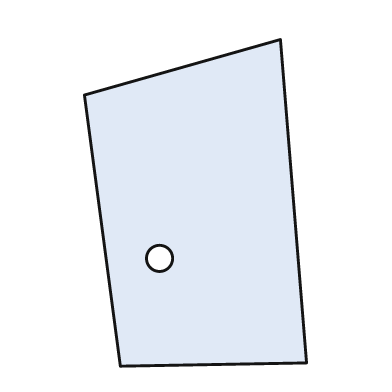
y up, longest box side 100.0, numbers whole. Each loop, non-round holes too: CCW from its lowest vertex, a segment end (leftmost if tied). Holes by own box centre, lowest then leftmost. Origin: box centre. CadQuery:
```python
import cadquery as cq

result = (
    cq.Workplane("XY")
    .moveTo(-23.0, -50.0)
    .lineTo(34.0, -49.0)
    .lineTo(26.0, 50.0)
    .lineTo(-34.0, 33.0)
    .close()
    .moveTo(-11.0, -17.0)
    .circle(4.0)
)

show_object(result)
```